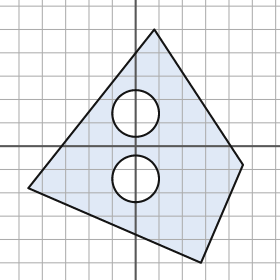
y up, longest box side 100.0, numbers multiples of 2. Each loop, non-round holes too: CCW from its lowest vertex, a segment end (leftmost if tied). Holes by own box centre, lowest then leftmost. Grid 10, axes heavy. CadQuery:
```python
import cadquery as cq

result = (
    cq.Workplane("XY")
    .moveTo(28.0, -50.0)
    .lineTo(46.0, -8.0)
    .lineTo(8.0, 50.0)
    .lineTo(-46.0, -18.0)
    .close()
    .moveTo(0.0, -14.0)
    .circle(10.0)
    .moveTo(0.0, 14.0)
    .circle(10.0)
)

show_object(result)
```